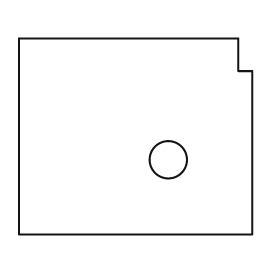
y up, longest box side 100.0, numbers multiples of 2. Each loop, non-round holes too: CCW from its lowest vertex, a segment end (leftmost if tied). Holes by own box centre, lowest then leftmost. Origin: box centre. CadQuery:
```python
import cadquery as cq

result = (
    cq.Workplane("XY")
    .moveTo(-50.0, -42.0)
    .lineTo(50.0, -42.0)
    .lineTo(50.0, 28.0)
    .lineTo(44.0, 28.0)
    .lineTo(44.0, 42.0)
    .lineTo(-50.0, 42.0)
    .close()
    .moveTo(14.0, -10.0)
    .circle(8.0)
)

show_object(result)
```